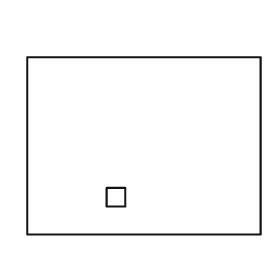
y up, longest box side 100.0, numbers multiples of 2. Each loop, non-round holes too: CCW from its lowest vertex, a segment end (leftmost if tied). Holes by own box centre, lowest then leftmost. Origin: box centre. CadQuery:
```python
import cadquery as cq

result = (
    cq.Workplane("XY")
    .moveTo(-50.0, -38.0)
    .lineTo(50.0, -38.0)
    .lineTo(50.0, 38.0)
    .lineTo(-50.0, 38.0)
    .close()
    .moveTo(-16.0, -26.0)
    .lineTo(-8.0, -26.0)
    .lineTo(-8.0, -18.0)
    .lineTo(-16.0, -18.0)
    .close()
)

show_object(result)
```